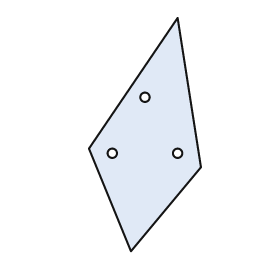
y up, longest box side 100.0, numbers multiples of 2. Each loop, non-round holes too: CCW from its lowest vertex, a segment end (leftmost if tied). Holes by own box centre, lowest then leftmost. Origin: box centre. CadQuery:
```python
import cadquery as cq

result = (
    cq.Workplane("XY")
    .moveTo(-6.0, -50.0)
    .lineTo(24.0, -14.0)
    .lineTo(14.0, 50.0)
    .lineTo(-24.0, -6.0)
    .close()
    .moveTo(-14.0, -8.0)
    .circle(2.0)
    .moveTo(14.0, -8.0)
    .circle(2.0)
    .moveTo(0.0, 16.0)
    .circle(2.0)
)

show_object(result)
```